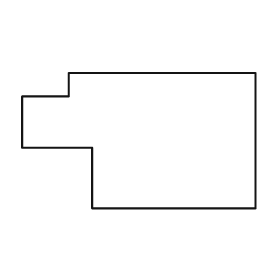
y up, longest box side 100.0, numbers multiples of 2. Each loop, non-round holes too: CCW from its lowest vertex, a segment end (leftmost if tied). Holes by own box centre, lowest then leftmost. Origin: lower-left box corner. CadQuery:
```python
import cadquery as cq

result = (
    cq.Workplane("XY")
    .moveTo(30.0, 0.0)
    .lineTo(100.0, 0.0)
    .lineTo(100.0, 58.0)
    .lineTo(20.0, 58.0)
    .lineTo(20.0, 48.0)
    .lineTo(0.0, 48.0)
    .lineTo(0.0, 26.0)
    .lineTo(30.0, 26.0)
    .close()
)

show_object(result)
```